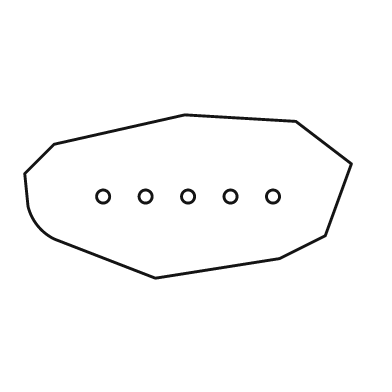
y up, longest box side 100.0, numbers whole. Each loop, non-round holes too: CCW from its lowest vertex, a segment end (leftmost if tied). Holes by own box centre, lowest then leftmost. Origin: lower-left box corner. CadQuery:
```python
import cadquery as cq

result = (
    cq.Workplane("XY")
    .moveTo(40.0, 0.0)
    .lineTo(78.0, 6.0)
    .lineTo(92.0, 13.0)
    .lineTo(100.0, 35.0)
    .lineTo(83.0, 48.0)
    .lineTo(49.0, 50.0)
    .lineTo(9.0, 41.0)
    .lineTo(0.0, 32.0)
    .lineTo(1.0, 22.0)
    .threePointArc((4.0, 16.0), (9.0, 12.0))
    .close()
    .moveTo(24.0, 25.0)
    .circle(2.0)
    .moveTo(37.0, 25.0)
    .circle(2.0)
    .moveTo(50.0, 25.0)
    .circle(2.0)
    .moveTo(63.0, 25.0)
    .circle(2.0)
    .moveTo(76.0, 25.0)
    .circle(2.0)
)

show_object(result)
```